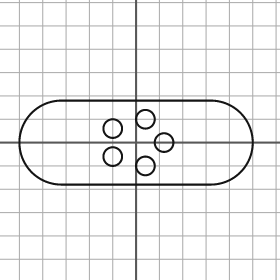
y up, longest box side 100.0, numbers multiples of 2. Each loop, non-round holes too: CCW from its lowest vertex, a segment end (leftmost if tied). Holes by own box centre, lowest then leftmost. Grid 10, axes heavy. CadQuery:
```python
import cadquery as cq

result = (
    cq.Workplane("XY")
    .moveTo(-32.0, -18.0)
    .lineTo(32.0, -18.0)
    .threePointArc((50.0, 0.0), (32.0, 18.0))
    .lineTo(-32.0, 18.0)
    .threePointArc((-50.0, 0.0), (-32.0, -18.0))
    .close()
    .moveTo(4.0, -10.0)
    .circle(4.0)
    .moveTo(-10.0, -6.0)
    .circle(4.0)
    .moveTo(12.0, 0.0)
    .circle(4.0)
    .moveTo(-10.0, 6.0)
    .circle(4.0)
    .moveTo(4.0, 10.0)
    .circle(4.0)
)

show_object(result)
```